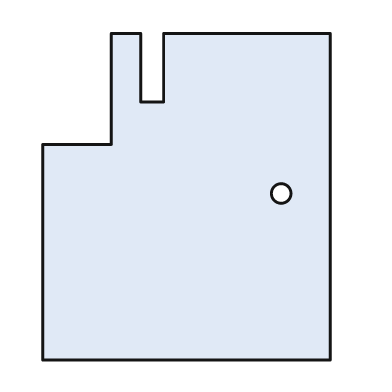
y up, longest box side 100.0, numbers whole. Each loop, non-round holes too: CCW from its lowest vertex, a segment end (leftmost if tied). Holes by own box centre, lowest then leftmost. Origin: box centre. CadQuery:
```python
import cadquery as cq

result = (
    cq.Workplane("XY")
    .moveTo(-44.0, -50.0)
    .lineTo(44.0, -50.0)
    .lineTo(44.0, 50.0)
    .lineTo(-7.0, 50.0)
    .lineTo(-7.0, 29.0)
    .lineTo(-14.0, 29.0)
    .lineTo(-14.0, 50.0)
    .lineTo(-23.0, 50.0)
    .lineTo(-23.0, 16.0)
    .lineTo(-44.0, 16.0)
    .close()
    .moveTo(29.0, 1.0)
    .circle(3.0)
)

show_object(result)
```